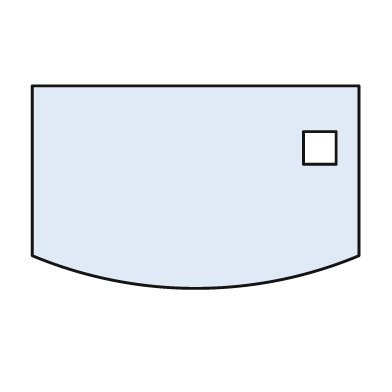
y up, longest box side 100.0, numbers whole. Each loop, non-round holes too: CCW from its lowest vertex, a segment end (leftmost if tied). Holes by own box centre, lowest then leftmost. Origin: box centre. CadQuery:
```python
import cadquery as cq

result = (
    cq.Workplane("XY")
    .moveTo(-50.0, -21.0)
    .threePointArc((0.0, -31.0), (50.0, -21.0))
    .lineTo(50.0, 31.0)
    .lineTo(-50.0, 31.0)
    .close()
    .moveTo(33.0, 7.0)
    .lineTo(43.0, 7.0)
    .lineTo(43.0, 17.0)
    .lineTo(33.0, 17.0)
    .close()
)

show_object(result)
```